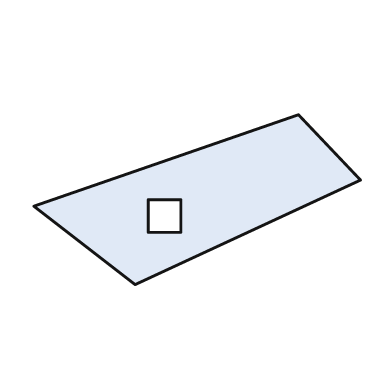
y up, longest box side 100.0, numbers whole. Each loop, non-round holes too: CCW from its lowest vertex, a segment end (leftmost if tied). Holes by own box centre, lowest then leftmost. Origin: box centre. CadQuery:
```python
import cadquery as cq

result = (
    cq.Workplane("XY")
    .moveTo(-19.0, -26.0)
    .lineTo(50.0, 6.0)
    .lineTo(31.0, 26.0)
    .lineTo(-50.0, -2.0)
    .close()
    .moveTo(-15.0, -10.0)
    .lineTo(-5.0, -10.0)
    .lineTo(-5.0, 0.0)
    .lineTo(-15.0, 0.0)
    .close()
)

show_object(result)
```